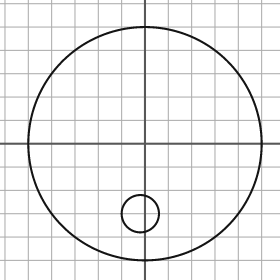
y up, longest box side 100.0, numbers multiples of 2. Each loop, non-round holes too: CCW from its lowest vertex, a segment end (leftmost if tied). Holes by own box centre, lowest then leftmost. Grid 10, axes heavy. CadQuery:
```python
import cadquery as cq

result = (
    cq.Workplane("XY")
    .moveTo(0.0, 0.0)
    .circle(50.0)
    .moveTo(-2.0, -30.0)
    .circle(8.0)
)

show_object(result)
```